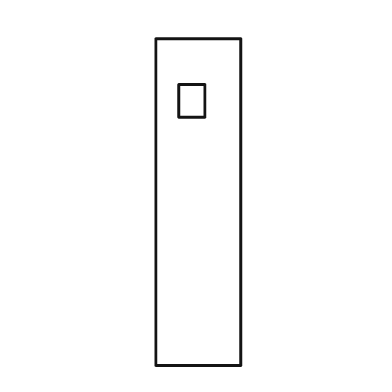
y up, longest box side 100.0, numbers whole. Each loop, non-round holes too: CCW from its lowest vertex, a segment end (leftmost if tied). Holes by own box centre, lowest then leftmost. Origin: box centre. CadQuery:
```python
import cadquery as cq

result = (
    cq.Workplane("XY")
    .moveTo(-13.0, -50.0)
    .lineTo(13.0, -50.0)
    .lineTo(13.0, 50.0)
    .lineTo(-13.0, 50.0)
    .close()
    .moveTo(-6.0, 26.0)
    .lineTo(2.0, 26.0)
    .lineTo(2.0, 36.0)
    .lineTo(-6.0, 36.0)
    .close()
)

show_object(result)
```